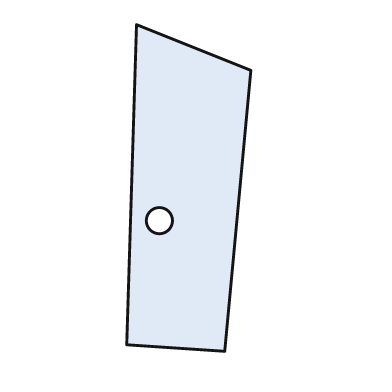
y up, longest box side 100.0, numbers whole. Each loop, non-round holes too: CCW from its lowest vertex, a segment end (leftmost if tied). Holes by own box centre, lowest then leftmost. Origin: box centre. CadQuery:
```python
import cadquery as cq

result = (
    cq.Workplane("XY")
    .moveTo(11.0, -50.0)
    .lineTo(19.0, 36.0)
    .lineTo(-16.0, 50.0)
    .lineTo(-19.0, -48.0)
    .close()
    .moveTo(-9.0, -10.0)
    .circle(4.0)
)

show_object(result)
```